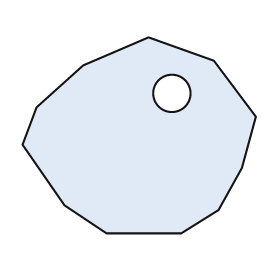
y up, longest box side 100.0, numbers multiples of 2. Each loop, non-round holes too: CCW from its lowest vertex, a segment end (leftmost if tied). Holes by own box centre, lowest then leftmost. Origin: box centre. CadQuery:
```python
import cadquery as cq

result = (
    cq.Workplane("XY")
    .moveTo(-14.0, -42.0)
    .lineTo(18.0, -42.0)
    .lineTo(34.0, -32.0)
    .lineTo(44.0, -14.0)
    .lineTo(50.0, 8.0)
    .lineTo(32.0, 32.0)
    .lineTo(4.0, 42.0)
    .lineTo(-24.0, 30.0)
    .lineTo(-44.0, 12.0)
    .lineTo(-50.0, -4.0)
    .lineTo(-32.0, -30.0)
    .close()
    .moveTo(14.0, 18.0)
    .circle(8.0)
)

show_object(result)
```